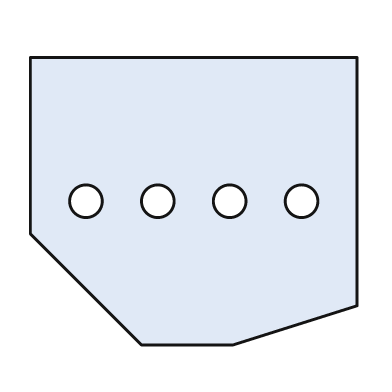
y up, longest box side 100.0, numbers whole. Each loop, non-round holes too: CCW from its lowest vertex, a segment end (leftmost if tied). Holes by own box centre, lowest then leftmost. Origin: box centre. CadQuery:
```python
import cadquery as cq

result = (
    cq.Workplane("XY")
    .moveTo(-16.0, -44.0)
    .lineTo(12.0, -44.0)
    .lineTo(50.0, -32.0)
    .lineTo(50.0, 44.0)
    .lineTo(-50.0, 44.0)
    .lineTo(-50.0, -10.0)
    .close()
    .moveTo(-33.0, 0.0)
    .circle(5.0)
    .moveTo(-11.0, 0.0)
    .circle(5.0)
    .moveTo(11.0, 0.0)
    .circle(5.0)
    .moveTo(33.0, 0.0)
    .circle(5.0)
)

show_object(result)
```